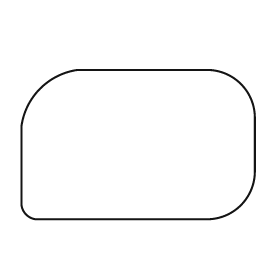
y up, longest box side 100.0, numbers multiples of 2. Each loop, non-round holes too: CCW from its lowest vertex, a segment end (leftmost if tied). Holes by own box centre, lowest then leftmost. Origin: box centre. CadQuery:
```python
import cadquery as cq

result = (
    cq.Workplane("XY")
    .moveTo(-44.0, -32.0)
    .lineTo(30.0, -32.0)
    .threePointArc((44.0, -26.0), (50.0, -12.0))
    .lineTo(50.0, 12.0)
    .threePointArc((44.0, 26.0), (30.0, 32.0))
    .lineTo(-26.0, 32.0)
    .threePointArc((-42.0, 24.0), (-50.0, 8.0))
    .lineTo(-50.0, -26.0)
    .threePointArc((-48.0, -30.0), (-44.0, -32.0))
    .close()
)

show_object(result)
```